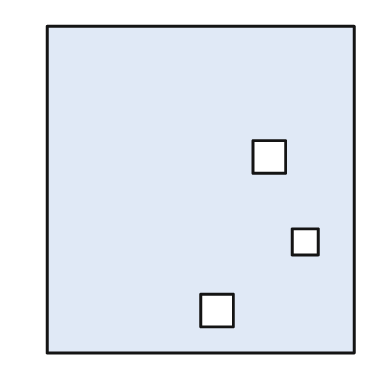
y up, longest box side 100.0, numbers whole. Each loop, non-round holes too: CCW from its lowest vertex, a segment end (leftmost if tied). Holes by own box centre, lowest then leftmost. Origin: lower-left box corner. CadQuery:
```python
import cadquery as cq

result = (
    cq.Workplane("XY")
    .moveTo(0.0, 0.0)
    .lineTo(94.0, 0.0)
    .lineTo(94.0, 100.0)
    .lineTo(0.0, 100.0)
    .close()
    .moveTo(47.0, 8.0)
    .lineTo(57.0, 8.0)
    .lineTo(57.0, 18.0)
    .lineTo(47.0, 18.0)
    .close()
    .moveTo(75.0, 30.0)
    .lineTo(83.0, 30.0)
    .lineTo(83.0, 38.0)
    .lineTo(75.0, 38.0)
    .close()
    .moveTo(63.0, 55.0)
    .lineTo(73.0, 55.0)
    .lineTo(73.0, 65.0)
    .lineTo(63.0, 65.0)
    .close()
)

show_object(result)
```